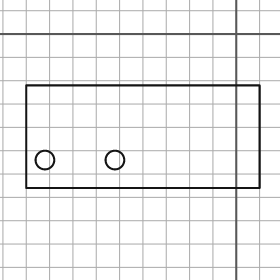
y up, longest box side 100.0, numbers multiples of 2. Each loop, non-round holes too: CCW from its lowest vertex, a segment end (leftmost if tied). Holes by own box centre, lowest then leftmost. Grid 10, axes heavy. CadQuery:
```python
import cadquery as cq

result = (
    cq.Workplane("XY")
    .moveTo(-90.0, -66.0)
    .lineTo(10.0, -66.0)
    .lineTo(10.0, -22.0)
    .lineTo(-90.0, -22.0)
    .close()
    .moveTo(-82.0, -54.0)
    .circle(4.0)
    .moveTo(-52.0, -54.0)
    .circle(4.0)
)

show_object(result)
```